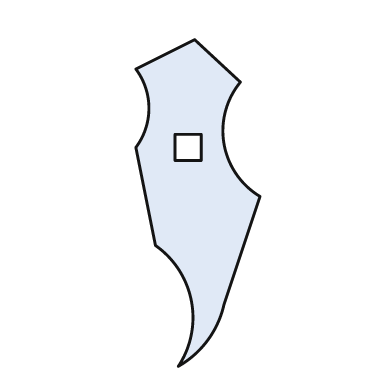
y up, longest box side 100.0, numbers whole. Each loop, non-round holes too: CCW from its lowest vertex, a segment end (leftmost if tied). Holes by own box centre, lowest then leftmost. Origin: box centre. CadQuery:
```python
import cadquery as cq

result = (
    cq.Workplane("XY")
    .moveTo(-6.0, -50.0)
    .threePointArc((3.0, -42.0), (8.0, -31.0))
    .lineTo(19.0, 2.0)
    .threePointArc((8.0, 18.0), (13.0, 37.0))
    .lineTo(-1.0, 50.0)
    .lineTo(-19.0, 41.0)
    .threePointArc((-15.0, 29.0), (-19.0, 17.0))
    .lineTo(-13.0, -13.0)
    .threePointArc((-2.0, -30.0), (-6.0, -50.0))
    .close()
    .moveTo(-7.0, 13.0)
    .lineTo(1.0, 13.0)
    .lineTo(1.0, 21.0)
    .lineTo(-7.0, 21.0)
    .close()
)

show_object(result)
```